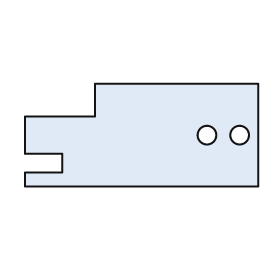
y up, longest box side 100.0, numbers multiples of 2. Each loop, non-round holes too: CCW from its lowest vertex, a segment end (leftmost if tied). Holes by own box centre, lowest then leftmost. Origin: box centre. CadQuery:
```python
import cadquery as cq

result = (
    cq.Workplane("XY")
    .moveTo(-50.0, -22.0)
    .lineTo(50.0, -22.0)
    .lineTo(50.0, 22.0)
    .lineTo(-20.0, 22.0)
    .lineTo(-20.0, 8.0)
    .lineTo(-50.0, 8.0)
    .lineTo(-50.0, -8.0)
    .lineTo(-34.0, -8.0)
    .lineTo(-34.0, -16.0)
    .lineTo(-50.0, -16.0)
    .close()
    .moveTo(28.0, 0.0)
    .circle(4.0)
    .moveTo(42.0, 0.0)
    .circle(4.0)
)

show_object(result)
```